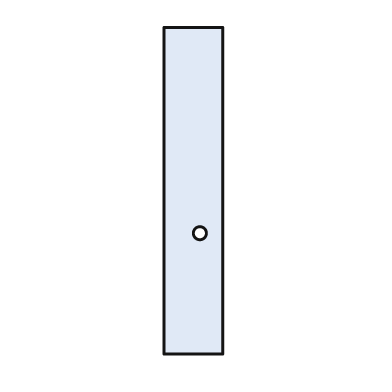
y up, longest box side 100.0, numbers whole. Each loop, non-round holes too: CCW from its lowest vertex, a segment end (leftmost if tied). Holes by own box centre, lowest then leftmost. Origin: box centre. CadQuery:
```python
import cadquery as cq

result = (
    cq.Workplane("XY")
    .moveTo(-9.0, -50.0)
    .lineTo(9.0, -50.0)
    .lineTo(9.0, 50.0)
    .lineTo(-9.0, 50.0)
    .close()
    .moveTo(2.0, -13.0)
    .circle(2.0)
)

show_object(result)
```